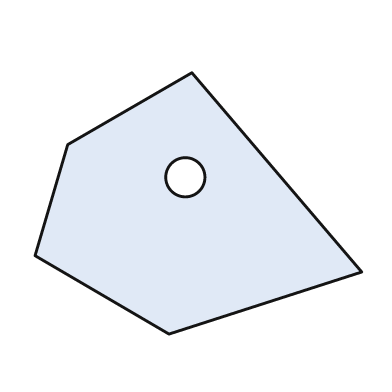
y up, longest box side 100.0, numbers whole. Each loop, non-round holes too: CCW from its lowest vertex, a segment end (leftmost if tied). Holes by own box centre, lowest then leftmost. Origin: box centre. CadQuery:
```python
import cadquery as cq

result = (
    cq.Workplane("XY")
    .moveTo(-9.0, -40.0)
    .lineTo(50.0, -21.0)
    .lineTo(-2.0, 40.0)
    .lineTo(-40.0, 18.0)
    .lineTo(-50.0, -16.0)
    .close()
    .moveTo(-4.0, 8.0)
    .circle(6.0)
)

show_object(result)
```